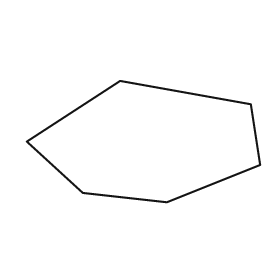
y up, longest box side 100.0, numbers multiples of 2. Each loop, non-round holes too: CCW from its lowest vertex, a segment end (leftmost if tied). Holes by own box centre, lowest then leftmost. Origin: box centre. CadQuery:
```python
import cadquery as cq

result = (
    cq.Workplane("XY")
    .moveTo(10.0, -26.0)
    .lineTo(50.0, -10.0)
    .lineTo(46.0, 16.0)
    .lineTo(-10.0, 26.0)
    .lineTo(-50.0, 0.0)
    .lineTo(-26.0, -22.0)
    .close()
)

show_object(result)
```